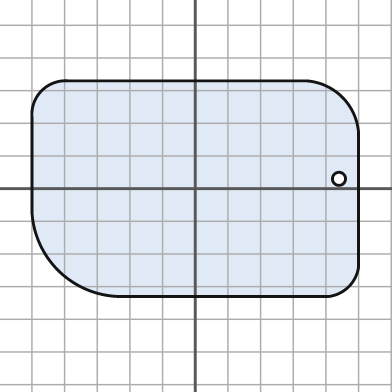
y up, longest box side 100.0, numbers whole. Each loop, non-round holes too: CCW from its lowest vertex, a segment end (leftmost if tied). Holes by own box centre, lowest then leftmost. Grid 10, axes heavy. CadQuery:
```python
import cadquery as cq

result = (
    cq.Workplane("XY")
    .moveTo(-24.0, -33.0)
    .lineTo(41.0, -33.0)
    .threePointArc((47.0, -30.0), (50.0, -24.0))
    .lineTo(50.0, 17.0)
    .threePointArc((45.0, 28.0), (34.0, 33.0))
    .lineTo(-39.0, 33.0)
    .threePointArc((-47.0, 30.0), (-50.0, 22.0))
    .lineTo(-50.0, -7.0)
    .threePointArc((-42.0, -25.0), (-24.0, -33.0))
    .close()
    .moveTo(44.0, 3.0)
    .circle(2.0)
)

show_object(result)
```